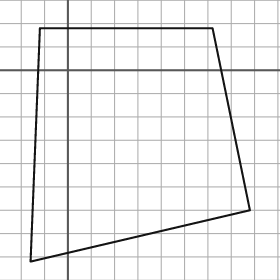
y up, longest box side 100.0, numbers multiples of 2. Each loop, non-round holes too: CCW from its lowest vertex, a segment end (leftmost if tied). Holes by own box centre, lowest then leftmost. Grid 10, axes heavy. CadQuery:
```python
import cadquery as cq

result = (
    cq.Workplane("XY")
    .moveTo(-16.0, -82.0)
    .lineTo(78.0, -60.0)
    .lineTo(62.0, 18.0)
    .lineTo(-12.0, 18.0)
    .close()
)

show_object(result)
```